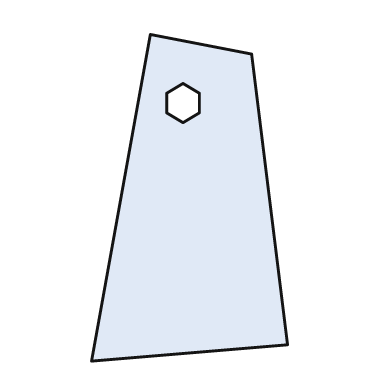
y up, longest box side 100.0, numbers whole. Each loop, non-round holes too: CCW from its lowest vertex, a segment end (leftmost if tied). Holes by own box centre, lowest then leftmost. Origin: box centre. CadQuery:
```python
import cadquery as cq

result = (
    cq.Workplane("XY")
    .moveTo(-30.0, -50.0)
    .lineTo(30.0, -45.0)
    .lineTo(19.0, 44.0)
    .lineTo(-12.0, 50.0)
    .close()
    .moveTo(-2.0, 23.0)
    .lineTo(3.0, 26.0)
    .lineTo(3.0, 32.0)
    .lineTo(-2.0, 35.0)
    .lineTo(-7.0, 32.0)
    .lineTo(-7.0, 26.0)
    .close()
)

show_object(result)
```